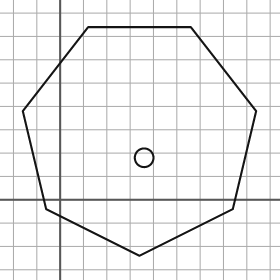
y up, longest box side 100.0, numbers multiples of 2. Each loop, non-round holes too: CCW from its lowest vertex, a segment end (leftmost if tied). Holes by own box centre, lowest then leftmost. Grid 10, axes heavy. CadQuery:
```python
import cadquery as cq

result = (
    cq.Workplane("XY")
    .moveTo(34.0, -24.0)
    .lineTo(74.0, -4.0)
    .lineTo(84.0, 38.0)
    .lineTo(56.0, 74.0)
    .lineTo(12.0, 74.0)
    .lineTo(-16.0, 38.0)
    .lineTo(-6.0, -4.0)
    .close()
    .moveTo(36.0, 18.0)
    .circle(4.0)
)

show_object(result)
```